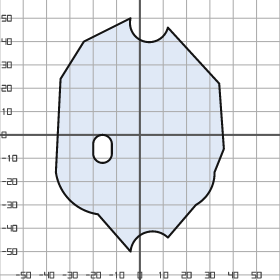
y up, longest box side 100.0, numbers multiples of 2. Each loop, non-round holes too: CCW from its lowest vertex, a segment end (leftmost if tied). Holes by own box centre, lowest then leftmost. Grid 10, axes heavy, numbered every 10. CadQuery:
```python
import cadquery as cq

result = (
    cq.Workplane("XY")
    .moveTo(-4.0, -50.0)
    .threePointArc((2.0, -42.0), (12.0, -44.0))
    .lineTo(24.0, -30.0)
    .threePointArc((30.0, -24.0), (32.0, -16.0))
    .lineTo(36.0, -6.0)
    .lineTo(34.0, 22.0)
    .lineTo(12.0, 46.0)
    .threePointArc((2.0, 40.0), (-4.0, 50.0))
    .lineTo(-24.0, 40.0)
    .lineTo(-34.0, 24.0)
    .lineTo(-36.0, -16.0)
    .threePointArc((-30.0, -28.0), (-18.0, -34.0))
    .close()
    .moveTo(-20.0, -8.0)
    .threePointArc((-16.0, -12.0), (-12.0, -8.0))
    .lineTo(-12.0, -4.0)
    .threePointArc((-16.0, 0.0), (-20.0, -4.0))
    .close()
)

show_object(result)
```